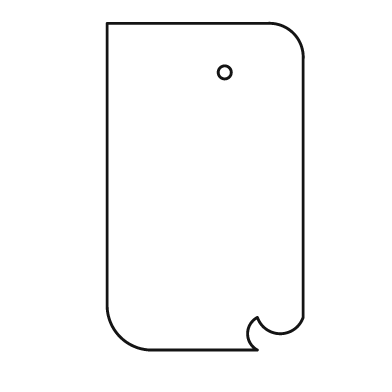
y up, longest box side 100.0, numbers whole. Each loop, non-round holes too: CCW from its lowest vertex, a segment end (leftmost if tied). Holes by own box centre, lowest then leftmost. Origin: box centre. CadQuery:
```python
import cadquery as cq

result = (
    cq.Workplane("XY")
    .moveTo(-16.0, -50.0)
    .lineTo(16.0, -50.0)
    .threePointArc((13.0, -45.0), (16.0, -40.0))
    .threePointArc((23.0, -45.0), (30.0, -40.0))
    .lineTo(30.0, 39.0)
    .threePointArc((27.0, 47.0), (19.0, 50.0))
    .lineTo(-30.0, 50.0)
    .lineTo(-30.0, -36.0)
    .threePointArc((-26.0, -46.0), (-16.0, -50.0))
    .close()
    .moveTo(6.0, 35.0)
    .circle(2.0)
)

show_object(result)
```